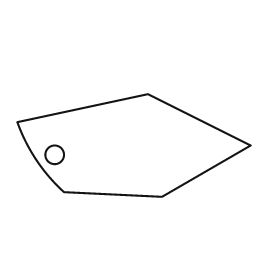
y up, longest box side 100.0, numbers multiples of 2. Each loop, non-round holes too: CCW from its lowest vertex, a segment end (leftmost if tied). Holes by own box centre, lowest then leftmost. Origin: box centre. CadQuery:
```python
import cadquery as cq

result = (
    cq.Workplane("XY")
    .moveTo(12.0, -22.0)
    .lineTo(50.0, 0.0)
    .lineTo(6.0, 22.0)
    .lineTo(-50.0, 10.0)
    .threePointArc((-42.0, -6.0), (-30.0, -20.0))
    .close()
    .moveTo(-34.0, -4.0)
    .circle(4.0)
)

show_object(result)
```